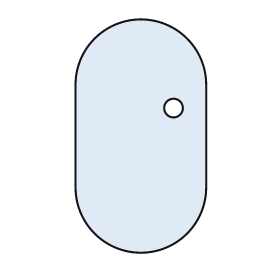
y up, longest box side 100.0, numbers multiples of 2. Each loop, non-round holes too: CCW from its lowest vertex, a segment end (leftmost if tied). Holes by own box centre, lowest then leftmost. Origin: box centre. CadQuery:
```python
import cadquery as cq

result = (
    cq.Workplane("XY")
    .moveTo(-28.0, -22.0)
    .threePointArc((0.0, -50.0), (28.0, -22.0))
    .lineTo(28.0, 22.0)
    .threePointArc((0.0, 50.0), (-28.0, 22.0))
    .close()
    .moveTo(14.0, 12.0)
    .circle(4.0)
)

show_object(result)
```